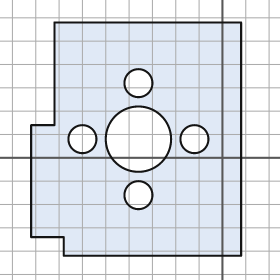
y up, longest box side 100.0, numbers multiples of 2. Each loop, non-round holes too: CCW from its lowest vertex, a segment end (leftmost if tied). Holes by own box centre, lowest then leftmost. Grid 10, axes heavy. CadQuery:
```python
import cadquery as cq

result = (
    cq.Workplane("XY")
    .moveTo(-68.0, -42.0)
    .lineTo(8.0, -42.0)
    .lineTo(8.0, 58.0)
    .lineTo(-72.0, 58.0)
    .lineTo(-72.0, 14.0)
    .lineTo(-82.0, 14.0)
    .lineTo(-82.0, -34.0)
    .lineTo(-68.0, -34.0)
    .close()
    .moveTo(-36.0, -16.0)
    .circle(6.0)
    .moveTo(-60.0, 8.0)
    .circle(6.0)
    .moveTo(-36.0, 8.0)
    .circle(14.0)
    .moveTo(-12.0, 8.0)
    .circle(6.0)
    .moveTo(-36.0, 32.0)
    .circle(6.0)
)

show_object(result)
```